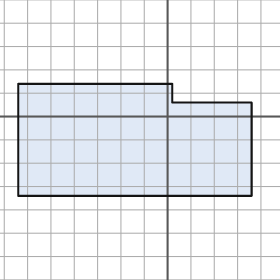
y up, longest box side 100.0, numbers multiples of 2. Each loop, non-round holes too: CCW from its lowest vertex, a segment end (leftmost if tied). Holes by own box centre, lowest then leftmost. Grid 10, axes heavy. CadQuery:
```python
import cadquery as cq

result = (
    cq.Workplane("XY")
    .moveTo(-64.0, -34.0)
    .lineTo(36.0, -34.0)
    .lineTo(36.0, 6.0)
    .lineTo(2.0, 6.0)
    .lineTo(2.0, 14.0)
    .lineTo(-64.0, 14.0)
    .close()
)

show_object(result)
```